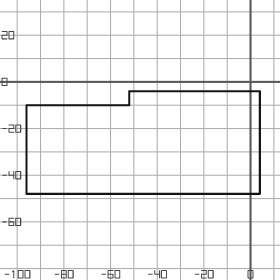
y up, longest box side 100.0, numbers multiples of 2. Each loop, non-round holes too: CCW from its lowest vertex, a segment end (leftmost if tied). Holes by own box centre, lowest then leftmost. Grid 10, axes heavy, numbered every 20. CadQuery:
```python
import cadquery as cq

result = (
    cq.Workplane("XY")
    .moveTo(-96.0, -48.0)
    .lineTo(4.0, -48.0)
    .lineTo(4.0, -4.0)
    .lineTo(-52.0, -4.0)
    .lineTo(-52.0, -10.0)
    .lineTo(-96.0, -10.0)
    .close()
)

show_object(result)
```